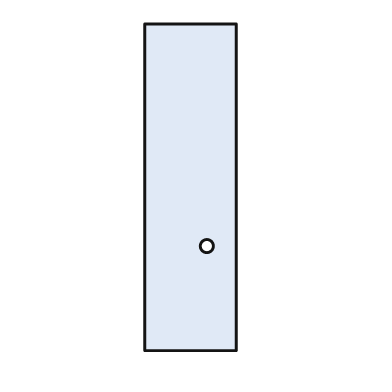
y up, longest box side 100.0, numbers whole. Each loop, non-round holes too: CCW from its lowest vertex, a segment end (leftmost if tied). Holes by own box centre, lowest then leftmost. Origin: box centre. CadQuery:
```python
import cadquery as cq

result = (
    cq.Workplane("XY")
    .moveTo(-14.0, -50.0)
    .lineTo(14.0, -50.0)
    .lineTo(14.0, 50.0)
    .lineTo(-14.0, 50.0)
    .close()
    .moveTo(5.0, -18.0)
    .circle(2.0)
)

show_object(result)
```